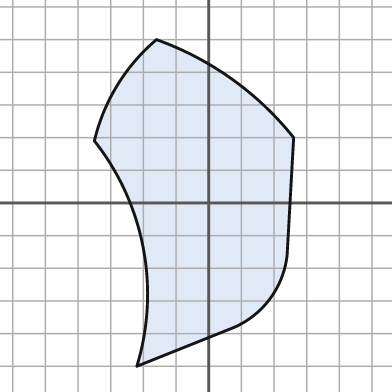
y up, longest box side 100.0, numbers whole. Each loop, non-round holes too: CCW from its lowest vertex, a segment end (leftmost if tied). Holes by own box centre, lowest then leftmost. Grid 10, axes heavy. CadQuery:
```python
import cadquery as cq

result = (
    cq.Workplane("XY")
    .moveTo(-22.0, -50.0)
    .lineTo(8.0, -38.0)
    .threePointArc((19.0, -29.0), (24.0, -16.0))
    .lineTo(26.0, 20.0)
    .threePointArc((7.0, 38.0), (-16.0, 50.0))
    .threePointArc((-28.0, 36.0), (-35.0, 19.0))
    .threePointArc((-20.0, -14.0), (-22.0, -50.0))
    .close()
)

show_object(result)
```